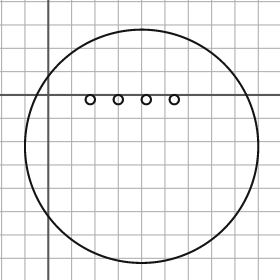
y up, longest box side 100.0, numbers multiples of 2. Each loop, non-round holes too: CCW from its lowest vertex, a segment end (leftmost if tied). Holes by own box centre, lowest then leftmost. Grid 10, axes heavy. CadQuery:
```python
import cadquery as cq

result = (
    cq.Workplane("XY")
    .moveTo(40.0, -22.0)
    .circle(50.0)
    .moveTo(18.0, -2.0)
    .circle(2.0)
    .moveTo(30.0, -2.0)
    .circle(2.0)
    .moveTo(42.0, -2.0)
    .circle(2.0)
    .moveTo(54.0, -2.0)
    .circle(2.0)
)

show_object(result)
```